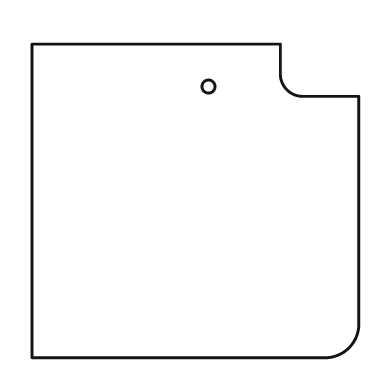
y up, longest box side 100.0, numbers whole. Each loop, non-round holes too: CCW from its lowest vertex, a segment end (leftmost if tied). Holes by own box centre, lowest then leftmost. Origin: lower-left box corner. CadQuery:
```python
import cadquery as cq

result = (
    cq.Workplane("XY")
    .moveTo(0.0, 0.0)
    .lineTo(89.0, 0.0)
    .threePointArc((97.0, 3.0), (100.0, 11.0))
    .lineTo(100.0, 80.0)
    .lineTo(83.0, 80.0)
    .threePointArc((78.0, 82.0), (76.0, 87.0))
    .lineTo(76.0, 96.0)
    .lineTo(0.0, 96.0)
    .close()
    .moveTo(54.0, 83.0)
    .circle(2.0)
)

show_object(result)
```